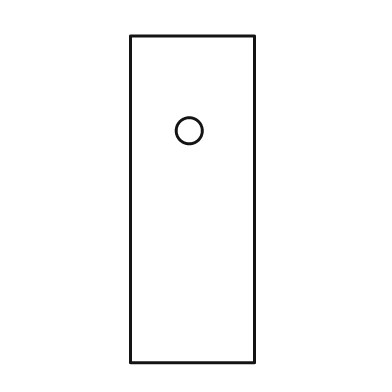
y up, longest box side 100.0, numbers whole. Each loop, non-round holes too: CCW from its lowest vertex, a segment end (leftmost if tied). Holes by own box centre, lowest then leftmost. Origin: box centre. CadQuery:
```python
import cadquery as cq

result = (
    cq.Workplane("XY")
    .moveTo(-19.0, -50.0)
    .lineTo(19.0, -50.0)
    .lineTo(19.0, 50.0)
    .lineTo(-19.0, 50.0)
    .close()
    .moveTo(-1.0, 21.0)
    .circle(4.0)
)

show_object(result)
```